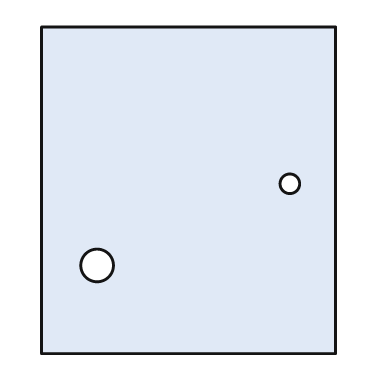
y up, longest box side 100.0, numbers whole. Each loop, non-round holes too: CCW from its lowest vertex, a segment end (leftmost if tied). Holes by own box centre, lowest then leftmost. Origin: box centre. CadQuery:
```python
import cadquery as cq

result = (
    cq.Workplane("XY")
    .moveTo(-45.0, -50.0)
    .lineTo(45.0, -50.0)
    .lineTo(45.0, 50.0)
    .lineTo(-45.0, 50.0)
    .close()
    .moveTo(-28.0, -23.0)
    .circle(5.0)
    .moveTo(31.0, 2.0)
    .circle(3.0)
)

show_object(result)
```